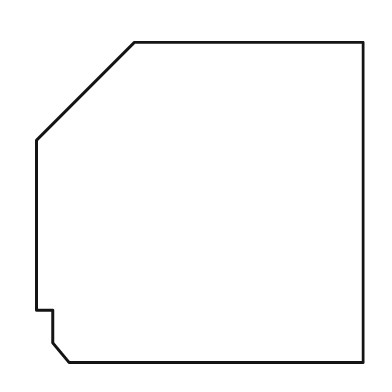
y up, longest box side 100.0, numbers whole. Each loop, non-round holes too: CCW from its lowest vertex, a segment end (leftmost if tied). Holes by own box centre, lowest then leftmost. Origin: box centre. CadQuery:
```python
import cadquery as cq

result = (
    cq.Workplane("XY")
    .moveTo(-40.0, -49.0)
    .lineTo(50.0, -49.0)
    .lineTo(50.0, 49.0)
    .lineTo(-20.0, 49.0)
    .lineTo(-50.0, 19.0)
    .lineTo(-50.0, -33.0)
    .lineTo(-45.0, -33.0)
    .lineTo(-45.0, -43.0)
    .close()
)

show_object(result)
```